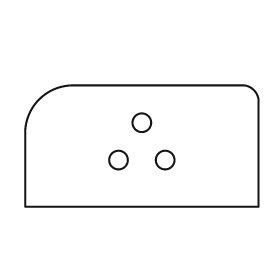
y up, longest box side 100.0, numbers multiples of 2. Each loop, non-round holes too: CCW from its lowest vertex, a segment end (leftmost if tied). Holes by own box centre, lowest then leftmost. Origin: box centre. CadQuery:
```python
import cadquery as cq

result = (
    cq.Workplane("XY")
    .moveTo(-50.0, -26.0)
    .lineTo(50.0, -26.0)
    .lineTo(50.0, 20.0)
    .threePointArc((48.0, 24.0), (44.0, 26.0))
    .lineTo(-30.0, 26.0)
    .threePointArc((-44.0, 20.0), (-50.0, 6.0))
    .close()
    .moveTo(-10.0, -6.0)
    .circle(4.0)
    .moveTo(10.0, -6.0)
    .circle(4.0)
    .moveTo(0.0, 10.0)
    .circle(4.0)
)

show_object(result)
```